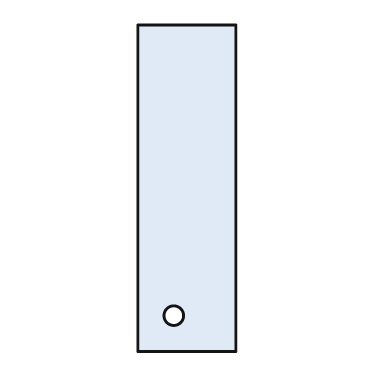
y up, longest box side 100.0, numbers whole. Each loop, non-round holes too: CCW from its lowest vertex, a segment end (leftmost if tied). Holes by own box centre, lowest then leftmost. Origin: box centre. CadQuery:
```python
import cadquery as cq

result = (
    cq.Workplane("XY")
    .moveTo(-15.0, -50.0)
    .lineTo(15.0, -50.0)
    .lineTo(15.0, 50.0)
    .lineTo(-15.0, 50.0)
    .close()
    .moveTo(-4.0, -39.0)
    .circle(3.0)
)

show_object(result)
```